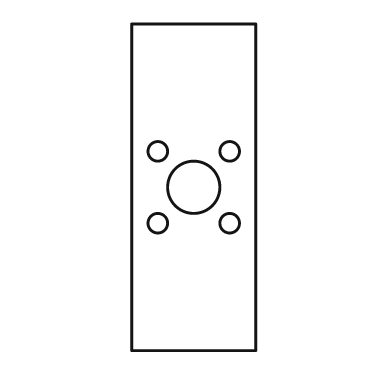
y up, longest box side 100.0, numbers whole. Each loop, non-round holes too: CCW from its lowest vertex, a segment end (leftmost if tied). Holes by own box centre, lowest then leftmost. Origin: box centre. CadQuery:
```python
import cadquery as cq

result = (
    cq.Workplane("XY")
    .moveTo(-19.0, -50.0)
    .lineTo(19.0, -50.0)
    .lineTo(19.0, 50.0)
    .lineTo(-19.0, 50.0)
    .close()
    .moveTo(-11.0, -11.0)
    .circle(3.0)
    .moveTo(11.0, -11.0)
    .circle(3.0)
    .moveTo(0.0, 0.0)
    .circle(8.0)
    .moveTo(-11.0, 11.0)
    .circle(3.0)
    .moveTo(11.0, 11.0)
    .circle(3.0)
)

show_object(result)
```